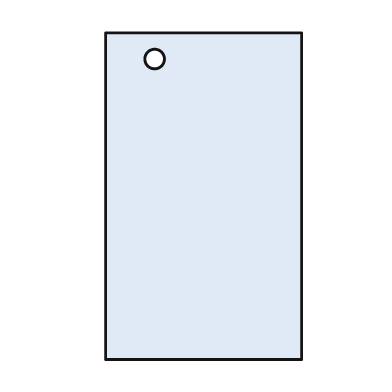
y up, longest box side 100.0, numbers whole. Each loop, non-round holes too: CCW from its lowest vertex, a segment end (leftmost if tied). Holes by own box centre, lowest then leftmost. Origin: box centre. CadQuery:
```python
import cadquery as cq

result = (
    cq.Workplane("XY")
    .moveTo(-30.0, -50.0)
    .lineTo(30.0, -50.0)
    .lineTo(30.0, 50.0)
    .lineTo(-30.0, 50.0)
    .close()
    .moveTo(-15.0, 42.0)
    .circle(3.0)
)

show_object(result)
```